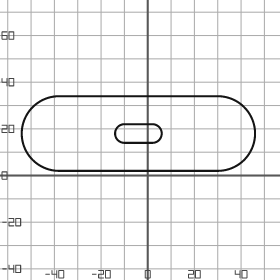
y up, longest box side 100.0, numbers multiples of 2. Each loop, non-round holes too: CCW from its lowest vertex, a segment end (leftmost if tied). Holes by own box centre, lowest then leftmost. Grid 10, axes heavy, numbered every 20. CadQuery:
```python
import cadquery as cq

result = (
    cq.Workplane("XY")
    .moveTo(-38.0, 2.0)
    .lineTo(30.0, 2.0)
    .threePointArc((46.0, 18.0), (30.0, 34.0))
    .lineTo(-38.0, 34.0)
    .threePointArc((-54.0, 18.0), (-38.0, 2.0))
    .close()
    .moveTo(-10.0, 14.0)
    .lineTo(2.0, 14.0)
    .threePointArc((6.0, 18.0), (2.0, 22.0))
    .lineTo(-10.0, 22.0)
    .threePointArc((-14.0, 18.0), (-10.0, 14.0))
    .close()
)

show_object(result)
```